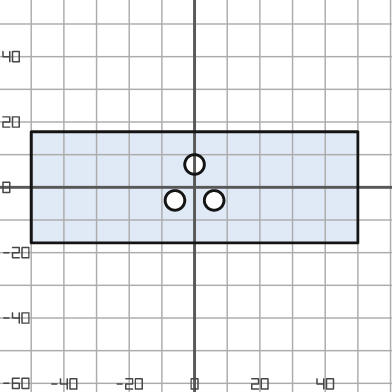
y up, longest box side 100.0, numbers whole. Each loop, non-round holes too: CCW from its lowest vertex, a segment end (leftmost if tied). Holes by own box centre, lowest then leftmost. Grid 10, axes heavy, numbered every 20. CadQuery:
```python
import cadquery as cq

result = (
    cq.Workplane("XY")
    .moveTo(-50.0, -17.0)
    .lineTo(50.0, -17.0)
    .lineTo(50.0, 17.0)
    .lineTo(-50.0, 17.0)
    .close()
    .moveTo(-6.0, -4.0)
    .circle(3.0)
    .moveTo(6.0, -4.0)
    .circle(3.0)
    .moveTo(0.0, 7.0)
    .circle(3.0)
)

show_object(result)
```